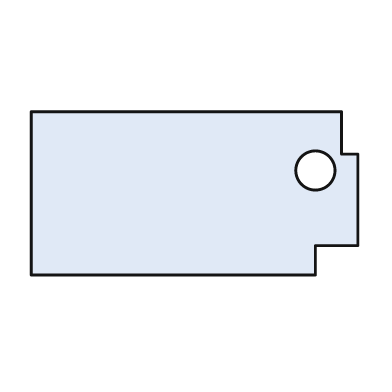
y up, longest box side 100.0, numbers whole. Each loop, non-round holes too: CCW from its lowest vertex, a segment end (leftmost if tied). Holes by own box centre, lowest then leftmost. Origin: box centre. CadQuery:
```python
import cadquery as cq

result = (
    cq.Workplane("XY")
    .moveTo(-50.0, -25.0)
    .lineTo(37.0, -25.0)
    .lineTo(37.0, -16.0)
    .lineTo(50.0, -16.0)
    .lineTo(50.0, 12.0)
    .lineTo(45.0, 12.0)
    .lineTo(45.0, 25.0)
    .lineTo(-50.0, 25.0)
    .close()
    .moveTo(37.0, 7.0)
    .circle(6.0)
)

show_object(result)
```